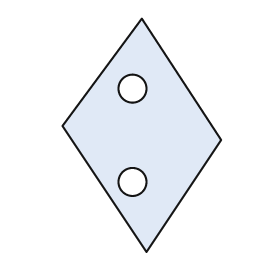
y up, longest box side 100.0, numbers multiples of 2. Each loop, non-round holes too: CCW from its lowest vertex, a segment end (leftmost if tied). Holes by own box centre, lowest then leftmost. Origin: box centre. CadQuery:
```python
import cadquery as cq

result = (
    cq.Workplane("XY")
    .moveTo(2.0, -50.0)
    .lineTo(34.0, -2.0)
    .lineTo(0.0, 50.0)
    .lineTo(-34.0, 4.0)
    .close()
    .moveTo(-4.0, -20.0)
    .circle(6.0)
    .moveTo(-4.0, 20.0)
    .circle(6.0)
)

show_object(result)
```